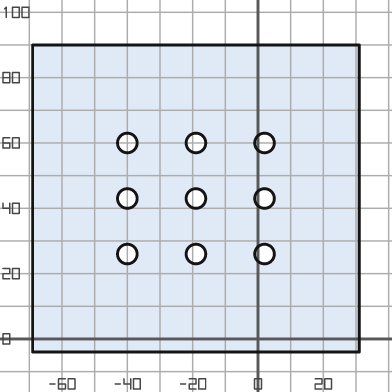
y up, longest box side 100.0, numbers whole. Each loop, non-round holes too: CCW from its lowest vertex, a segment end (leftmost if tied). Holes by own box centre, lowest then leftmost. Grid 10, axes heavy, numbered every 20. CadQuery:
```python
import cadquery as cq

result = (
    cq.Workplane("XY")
    .moveTo(-69.0, -4.0)
    .lineTo(31.0, -4.0)
    .lineTo(31.0, 90.0)
    .lineTo(-69.0, 90.0)
    .close()
    .moveTo(-40.0, 26.0)
    .circle(3.0)
    .moveTo(-19.0, 26.0)
    .circle(3.0)
    .moveTo(2.0, 26.0)
    .circle(3.0)
    .moveTo(-40.0, 43.0)
    .circle(3.0)
    .moveTo(-19.0, 43.0)
    .circle(3.0)
    .moveTo(2.0, 43.0)
    .circle(3.0)
    .moveTo(-40.0, 60.0)
    .circle(3.0)
    .moveTo(-19.0, 60.0)
    .circle(3.0)
    .moveTo(2.0, 60.0)
    .circle(3.0)
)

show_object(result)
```